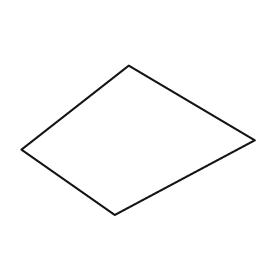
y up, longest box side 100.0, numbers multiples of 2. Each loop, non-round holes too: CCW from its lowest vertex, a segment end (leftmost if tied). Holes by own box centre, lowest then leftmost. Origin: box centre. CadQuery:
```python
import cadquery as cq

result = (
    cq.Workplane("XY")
    .moveTo(-10.0, -32.0)
    .lineTo(50.0, 0.0)
    .lineTo(-4.0, 32.0)
    .lineTo(-50.0, -4.0)
    .close()
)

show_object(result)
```